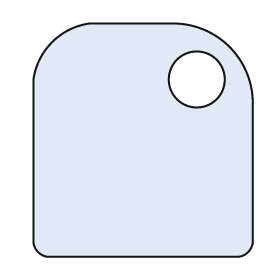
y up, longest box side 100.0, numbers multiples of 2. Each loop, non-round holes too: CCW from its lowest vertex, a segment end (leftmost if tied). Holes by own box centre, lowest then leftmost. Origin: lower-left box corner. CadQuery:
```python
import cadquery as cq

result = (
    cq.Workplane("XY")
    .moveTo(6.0, 0.0)
    .lineTo(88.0, 0.0)
    .threePointArc((92.0, 2.0), (94.0, 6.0))
    .lineTo(94.0, 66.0)
    .threePointArc((84.0, 90.0), (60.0, 100.0))
    .lineTo(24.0, 100.0)
    .threePointArc((8.0, 92.0), (0.0, 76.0))
    .lineTo(0.0, 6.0)
    .threePointArc((2.0, 2.0), (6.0, 0.0))
    .close()
    .moveTo(70.0, 76.0)
    .circle(12.0)
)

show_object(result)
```